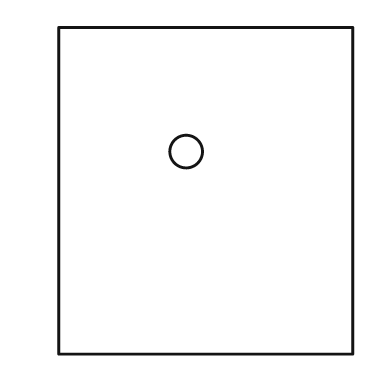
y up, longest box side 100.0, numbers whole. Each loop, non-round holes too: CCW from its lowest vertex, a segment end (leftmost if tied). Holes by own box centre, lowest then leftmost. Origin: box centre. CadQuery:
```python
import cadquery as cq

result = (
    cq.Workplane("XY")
    .moveTo(-45.0, -50.0)
    .lineTo(45.0, -50.0)
    .lineTo(45.0, 50.0)
    .lineTo(-45.0, 50.0)
    .close()
    .moveTo(-6.0, 12.0)
    .circle(5.0)
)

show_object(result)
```